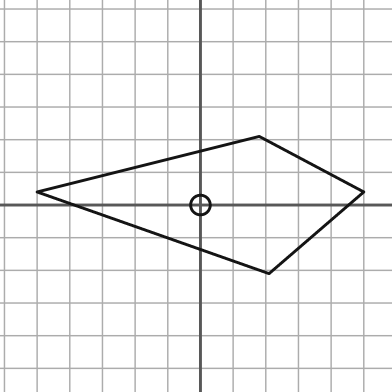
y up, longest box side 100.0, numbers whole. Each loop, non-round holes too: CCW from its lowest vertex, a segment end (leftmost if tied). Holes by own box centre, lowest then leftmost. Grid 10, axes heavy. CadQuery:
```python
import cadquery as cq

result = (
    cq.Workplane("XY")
    .moveTo(21.0, -21.0)
    .lineTo(50.0, 4.0)
    .lineTo(18.0, 21.0)
    .lineTo(-50.0, 4.0)
    .close()
    .moveTo(0.0, 0.0)
    .circle(3.0)
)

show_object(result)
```